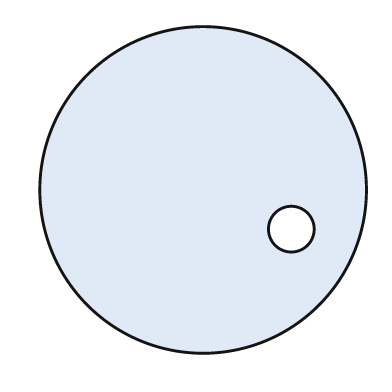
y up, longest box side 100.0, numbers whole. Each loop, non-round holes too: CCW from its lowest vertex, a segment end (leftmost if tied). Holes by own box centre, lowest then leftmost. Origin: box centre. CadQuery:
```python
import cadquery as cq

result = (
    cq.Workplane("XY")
    .moveTo(0.0, 0.0)
    .circle(50.0)
    .moveTo(27.0, -12.0)
    .circle(7.0)
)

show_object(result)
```